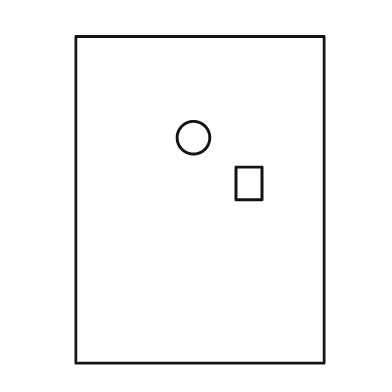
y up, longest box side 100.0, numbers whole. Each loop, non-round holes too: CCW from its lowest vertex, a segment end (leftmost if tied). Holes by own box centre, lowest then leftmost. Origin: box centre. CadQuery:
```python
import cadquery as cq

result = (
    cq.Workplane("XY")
    .moveTo(-38.0, -50.0)
    .lineTo(38.0, -50.0)
    .lineTo(38.0, 50.0)
    .lineTo(-38.0, 50.0)
    .close()
    .moveTo(11.0, 0.0)
    .lineTo(19.0, 0.0)
    .lineTo(19.0, 10.0)
    .lineTo(11.0, 10.0)
    .close()
    .moveTo(-2.0, 19.0)
    .circle(5.0)
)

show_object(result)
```